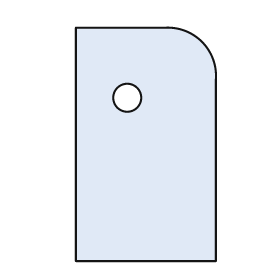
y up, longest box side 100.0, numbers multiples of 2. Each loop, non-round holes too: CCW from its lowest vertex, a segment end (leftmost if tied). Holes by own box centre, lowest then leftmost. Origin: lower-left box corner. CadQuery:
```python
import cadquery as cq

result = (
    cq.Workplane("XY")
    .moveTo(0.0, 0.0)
    .lineTo(60.0, 0.0)
    .lineTo(60.0, 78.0)
    .threePointArc((54.0, 94.0), (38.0, 100.0))
    .lineTo(0.0, 100.0)
    .close()
    .moveTo(22.0, 70.0)
    .circle(6.0)
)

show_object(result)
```